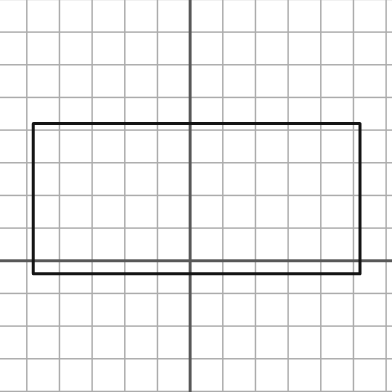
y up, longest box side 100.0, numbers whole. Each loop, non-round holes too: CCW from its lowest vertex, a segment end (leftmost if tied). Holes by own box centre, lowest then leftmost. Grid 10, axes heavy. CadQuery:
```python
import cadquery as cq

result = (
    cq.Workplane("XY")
    .moveTo(-48.0, -4.0)
    .lineTo(52.0, -4.0)
    .lineTo(52.0, 42.0)
    .lineTo(-48.0, 42.0)
    .close()
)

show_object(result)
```